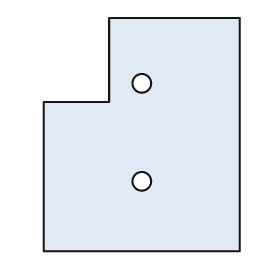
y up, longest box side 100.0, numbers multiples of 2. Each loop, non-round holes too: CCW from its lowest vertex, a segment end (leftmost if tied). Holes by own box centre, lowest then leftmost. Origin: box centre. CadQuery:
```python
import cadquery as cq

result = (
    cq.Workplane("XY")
    .moveTo(-42.0, -50.0)
    .lineTo(42.0, -50.0)
    .lineTo(42.0, 50.0)
    .lineTo(-14.0, 50.0)
    .lineTo(-14.0, 14.0)
    .lineTo(-42.0, 14.0)
    .close()
    .moveTo(0.0, -20.0)
    .circle(4.0)
    .moveTo(0.0, 22.0)
    .circle(4.0)
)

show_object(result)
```